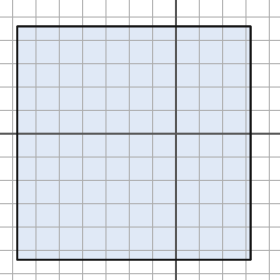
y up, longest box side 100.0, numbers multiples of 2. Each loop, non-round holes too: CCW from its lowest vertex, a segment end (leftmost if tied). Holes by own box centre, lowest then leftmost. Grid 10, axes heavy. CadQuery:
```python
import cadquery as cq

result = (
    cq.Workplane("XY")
    .moveTo(-68.0, -54.0)
    .lineTo(32.0, -54.0)
    .lineTo(32.0, 46.0)
    .lineTo(-68.0, 46.0)
    .close()
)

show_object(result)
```